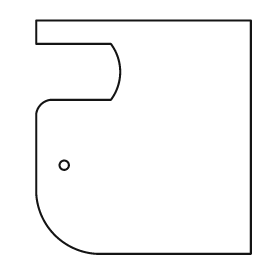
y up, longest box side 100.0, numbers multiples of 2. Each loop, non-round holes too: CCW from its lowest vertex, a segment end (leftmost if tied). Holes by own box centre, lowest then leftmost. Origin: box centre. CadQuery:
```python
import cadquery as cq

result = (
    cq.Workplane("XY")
    .moveTo(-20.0, -50.0)
    .lineTo(46.0, -50.0)
    .lineTo(46.0, 50.0)
    .lineTo(-46.0, 50.0)
    .lineTo(-46.0, 40.0)
    .lineTo(-14.0, 40.0)
    .threePointArc((-10.0, 28.0), (-14.0, 16.0))
    .lineTo(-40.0, 16.0)
    .threePointArc((-44.0, 14.0), (-46.0, 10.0))
    .lineTo(-46.0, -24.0)
    .threePointArc((-38.0, -42.0), (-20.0, -50.0))
    .close()
    .moveTo(-34.0, -12.0)
    .circle(2.0)
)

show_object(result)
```